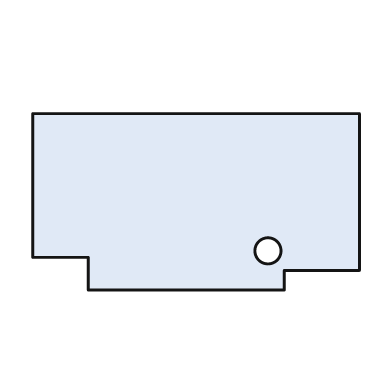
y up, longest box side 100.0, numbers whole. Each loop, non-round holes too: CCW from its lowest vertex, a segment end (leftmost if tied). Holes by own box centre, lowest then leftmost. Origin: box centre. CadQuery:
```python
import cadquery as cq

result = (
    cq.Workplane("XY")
    .moveTo(-33.0, -27.0)
    .lineTo(27.0, -27.0)
    .lineTo(27.0, -21.0)
    .lineTo(50.0, -21.0)
    .lineTo(50.0, 27.0)
    .lineTo(-50.0, 27.0)
    .lineTo(-50.0, -17.0)
    .lineTo(-33.0, -17.0)
    .close()
    .moveTo(22.0, -15.0)
    .circle(4.0)
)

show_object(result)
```